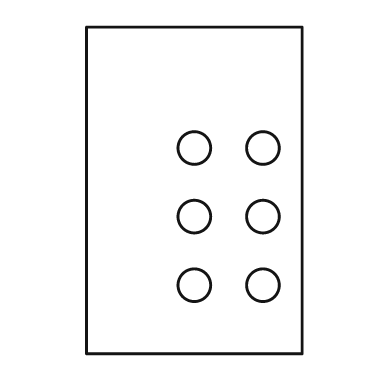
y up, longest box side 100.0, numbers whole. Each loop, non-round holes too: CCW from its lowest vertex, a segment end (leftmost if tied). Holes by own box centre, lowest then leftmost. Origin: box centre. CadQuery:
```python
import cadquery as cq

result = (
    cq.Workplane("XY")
    .moveTo(-33.0, -50.0)
    .lineTo(33.0, -50.0)
    .lineTo(33.0, 50.0)
    .lineTo(-33.0, 50.0)
    .close()
    .moveTo(0.0, -29.0)
    .circle(5.0)
    .moveTo(21.0, -29.0)
    .circle(5.0)
    .moveTo(0.0, -8.0)
    .circle(5.0)
    .moveTo(21.0, -8.0)
    .circle(5.0)
    .moveTo(0.0, 13.0)
    .circle(5.0)
    .moveTo(21.0, 13.0)
    .circle(5.0)
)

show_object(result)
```